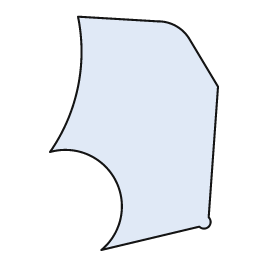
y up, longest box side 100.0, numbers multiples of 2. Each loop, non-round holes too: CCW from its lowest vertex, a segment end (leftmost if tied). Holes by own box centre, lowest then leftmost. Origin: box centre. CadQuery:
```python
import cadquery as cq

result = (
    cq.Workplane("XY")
    .moveTo(-14.0, -50.0)
    .lineTo(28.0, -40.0)
    .threePointArc((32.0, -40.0), (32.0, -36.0))
    .lineTo(36.0, 20.0)
    .lineTo(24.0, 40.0)
    .threePointArc((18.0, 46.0), (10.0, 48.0))
    .lineTo(-24.0, 50.0)
    .threePointArc((-24.0, 20.0), (-36.0, -8.0))
    .threePointArc((-8.0, -20.0), (-14.0, -50.0))
    .close()
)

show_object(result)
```